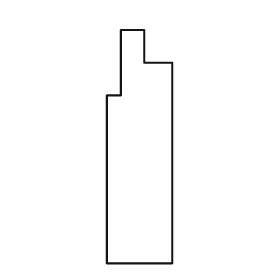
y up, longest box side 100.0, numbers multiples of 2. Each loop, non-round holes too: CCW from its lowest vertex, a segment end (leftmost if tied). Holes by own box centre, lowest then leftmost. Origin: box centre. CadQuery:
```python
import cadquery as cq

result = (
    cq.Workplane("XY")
    .moveTo(-14.0, -50.0)
    .lineTo(14.0, -50.0)
    .lineTo(14.0, 36.0)
    .lineTo(2.0, 36.0)
    .lineTo(2.0, 50.0)
    .lineTo(-8.0, 50.0)
    .lineTo(-8.0, 22.0)
    .lineTo(-14.0, 22.0)
    .close()
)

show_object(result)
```